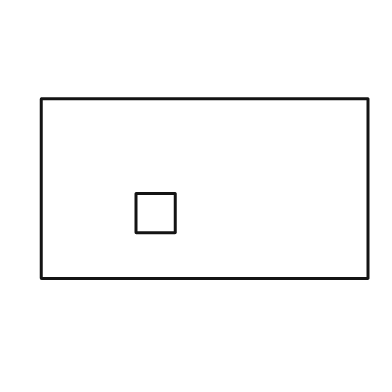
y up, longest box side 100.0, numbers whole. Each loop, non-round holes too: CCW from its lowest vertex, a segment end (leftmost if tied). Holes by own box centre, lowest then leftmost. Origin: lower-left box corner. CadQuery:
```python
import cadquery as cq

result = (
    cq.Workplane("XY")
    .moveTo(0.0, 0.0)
    .lineTo(100.0, 0.0)
    .lineTo(100.0, 55.0)
    .lineTo(0.0, 55.0)
    .close()
    .moveTo(29.0, 14.0)
    .lineTo(41.0, 14.0)
    .lineTo(41.0, 26.0)
    .lineTo(29.0, 26.0)
    .close()
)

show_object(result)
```